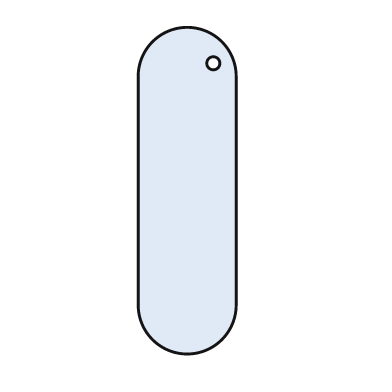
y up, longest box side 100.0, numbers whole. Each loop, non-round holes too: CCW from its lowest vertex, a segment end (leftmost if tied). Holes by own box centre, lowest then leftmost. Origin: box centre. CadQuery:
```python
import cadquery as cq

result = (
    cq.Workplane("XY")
    .moveTo(-15.0, -35.0)
    .threePointArc((0.0, -50.0), (15.0, -35.0))
    .lineTo(15.0, 35.0)
    .threePointArc((0.0, 50.0), (-15.0, 35.0))
    .close()
    .moveTo(8.0, 39.0)
    .circle(2.0)
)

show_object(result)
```